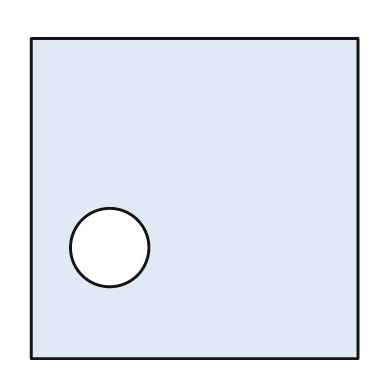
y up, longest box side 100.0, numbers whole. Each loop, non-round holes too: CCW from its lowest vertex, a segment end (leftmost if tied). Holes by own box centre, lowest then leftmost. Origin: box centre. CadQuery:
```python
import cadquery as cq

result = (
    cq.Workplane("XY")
    .moveTo(-50.0, -49.0)
    .lineTo(50.0, -49.0)
    .lineTo(50.0, 49.0)
    .lineTo(-50.0, 49.0)
    .close()
    .moveTo(-26.0, -15.0)
    .circle(12.0)
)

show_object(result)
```